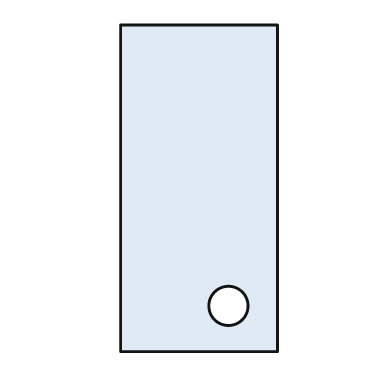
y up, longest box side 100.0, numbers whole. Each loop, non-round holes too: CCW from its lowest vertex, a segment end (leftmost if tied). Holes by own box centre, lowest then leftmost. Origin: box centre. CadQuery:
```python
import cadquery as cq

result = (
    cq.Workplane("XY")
    .moveTo(-24.0, -50.0)
    .lineTo(24.0, -50.0)
    .lineTo(24.0, 50.0)
    .lineTo(-24.0, 50.0)
    .close()
    .moveTo(9.0, -36.0)
    .circle(6.0)
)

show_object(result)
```